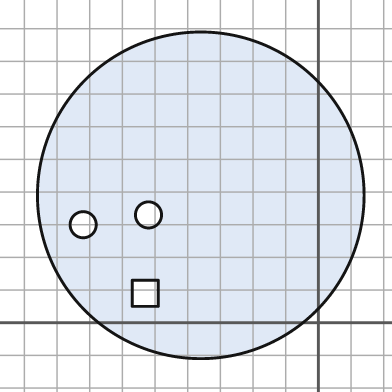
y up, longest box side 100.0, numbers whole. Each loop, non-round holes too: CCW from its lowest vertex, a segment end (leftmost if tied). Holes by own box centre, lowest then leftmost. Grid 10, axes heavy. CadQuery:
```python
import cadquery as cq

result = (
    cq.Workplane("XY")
    .moveTo(-36.0, 39.0)
    .circle(50.0)
    .moveTo(-57.0, 5.0)
    .lineTo(-49.0, 5.0)
    .lineTo(-49.0, 13.0)
    .lineTo(-57.0, 13.0)
    .close()
    .moveTo(-72.0, 30.0)
    .circle(4.0)
    .moveTo(-52.0, 33.0)
    .circle(4.0)
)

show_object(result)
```